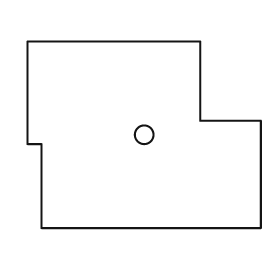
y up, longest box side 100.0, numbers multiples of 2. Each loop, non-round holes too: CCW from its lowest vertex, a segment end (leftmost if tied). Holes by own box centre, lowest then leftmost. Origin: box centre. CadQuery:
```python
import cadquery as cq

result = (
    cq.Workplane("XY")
    .moveTo(-44.0, -40.0)
    .lineTo(50.0, -40.0)
    .lineTo(50.0, 6.0)
    .lineTo(24.0, 6.0)
    .lineTo(24.0, 40.0)
    .lineTo(-50.0, 40.0)
    .lineTo(-50.0, -4.0)
    .lineTo(-44.0, -4.0)
    .close()
    .moveTo(0.0, 0.0)
    .circle(4.0)
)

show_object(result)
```